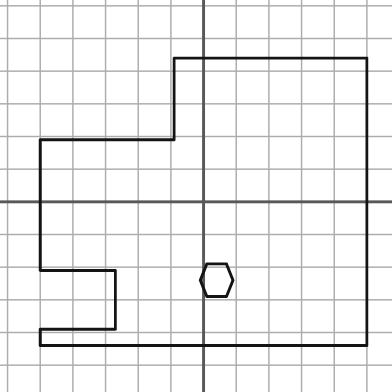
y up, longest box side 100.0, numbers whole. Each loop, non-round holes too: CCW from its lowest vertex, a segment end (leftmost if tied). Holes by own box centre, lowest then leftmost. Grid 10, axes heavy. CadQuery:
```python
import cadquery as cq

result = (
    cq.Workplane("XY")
    .moveTo(-50.0, -44.0)
    .lineTo(50.0, -44.0)
    .lineTo(50.0, 44.0)
    .lineTo(-9.0, 44.0)
    .lineTo(-9.0, 19.0)
    .lineTo(-50.0, 19.0)
    .lineTo(-50.0, -21.0)
    .lineTo(-27.0, -21.0)
    .lineTo(-27.0, -39.0)
    .lineTo(-50.0, -39.0)
    .close()
    .moveTo(1.0, -29.0)
    .lineTo(7.0, -29.0)
    .lineTo(9.0, -24.0)
    .lineTo(7.0, -19.0)
    .lineTo(1.0, -19.0)
    .lineTo(-1.0, -24.0)
    .close()
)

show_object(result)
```